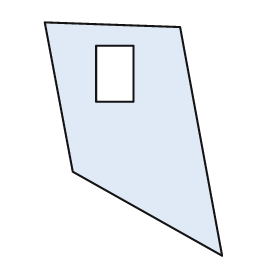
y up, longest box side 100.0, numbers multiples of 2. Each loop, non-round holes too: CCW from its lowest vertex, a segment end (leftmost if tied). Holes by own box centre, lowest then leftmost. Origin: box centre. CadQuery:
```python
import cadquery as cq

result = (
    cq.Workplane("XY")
    .moveTo(38.0, -50.0)
    .lineTo(20.0, 48.0)
    .lineTo(-38.0, 50.0)
    .lineTo(-26.0, -14.0)
    .close()
    .moveTo(-16.0, 16.0)
    .lineTo(0.0, 16.0)
    .lineTo(0.0, 40.0)
    .lineTo(-16.0, 40.0)
    .close()
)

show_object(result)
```